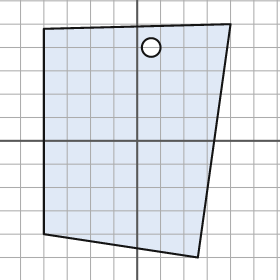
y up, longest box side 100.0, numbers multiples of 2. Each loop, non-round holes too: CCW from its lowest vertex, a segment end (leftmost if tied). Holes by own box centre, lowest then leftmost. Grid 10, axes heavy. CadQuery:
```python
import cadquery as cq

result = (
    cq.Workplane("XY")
    .moveTo(26.0, -50.0)
    .lineTo(40.0, 50.0)
    .lineTo(-40.0, 48.0)
    .lineTo(-40.0, -40.0)
    .close()
    .moveTo(6.0, 40.0)
    .circle(4.0)
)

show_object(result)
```